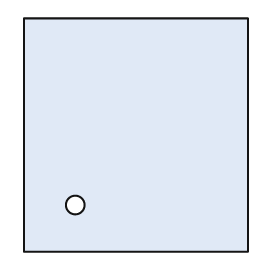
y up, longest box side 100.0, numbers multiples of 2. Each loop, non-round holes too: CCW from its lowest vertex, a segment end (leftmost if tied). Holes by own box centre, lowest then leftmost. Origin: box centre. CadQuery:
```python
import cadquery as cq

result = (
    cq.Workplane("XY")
    .moveTo(-48.0, -50.0)
    .lineTo(48.0, -50.0)
    .lineTo(48.0, 50.0)
    .lineTo(-48.0, 50.0)
    .close()
    .moveTo(-26.0, -30.0)
    .circle(4.0)
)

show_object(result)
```